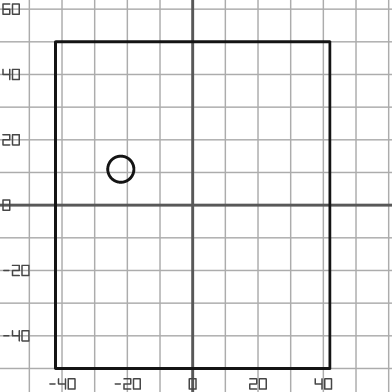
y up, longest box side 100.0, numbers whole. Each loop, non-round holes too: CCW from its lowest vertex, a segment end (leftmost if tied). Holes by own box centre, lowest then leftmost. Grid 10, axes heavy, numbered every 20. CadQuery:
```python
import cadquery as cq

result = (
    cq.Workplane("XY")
    .moveTo(-42.0, -50.0)
    .lineTo(42.0, -50.0)
    .lineTo(42.0, 50.0)
    .lineTo(-42.0, 50.0)
    .close()
    .moveTo(-22.0, 11.0)
    .circle(4.0)
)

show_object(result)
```